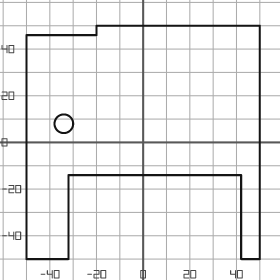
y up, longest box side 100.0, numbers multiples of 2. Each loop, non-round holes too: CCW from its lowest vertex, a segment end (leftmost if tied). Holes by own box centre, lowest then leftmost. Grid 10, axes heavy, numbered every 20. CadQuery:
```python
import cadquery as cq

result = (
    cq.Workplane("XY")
    .moveTo(-50.0, -50.0)
    .lineTo(-32.0, -50.0)
    .lineTo(-32.0, -14.0)
    .lineTo(42.0, -14.0)
    .lineTo(42.0, -50.0)
    .lineTo(50.0, -50.0)
    .lineTo(50.0, 50.0)
    .lineTo(-20.0, 50.0)
    .lineTo(-20.0, 46.0)
    .lineTo(-50.0, 46.0)
    .close()
    .moveTo(-34.0, 8.0)
    .circle(4.0)
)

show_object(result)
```